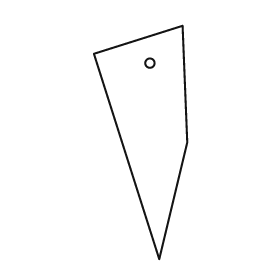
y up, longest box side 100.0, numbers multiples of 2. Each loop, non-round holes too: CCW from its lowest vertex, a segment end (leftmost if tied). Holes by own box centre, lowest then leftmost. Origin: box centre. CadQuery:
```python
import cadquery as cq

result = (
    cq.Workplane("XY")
    .moveTo(8.0, -50.0)
    .lineTo(20.0, 0.0)
    .lineTo(18.0, 50.0)
    .lineTo(-20.0, 38.0)
    .close()
    .moveTo(4.0, 34.0)
    .circle(2.0)
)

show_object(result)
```